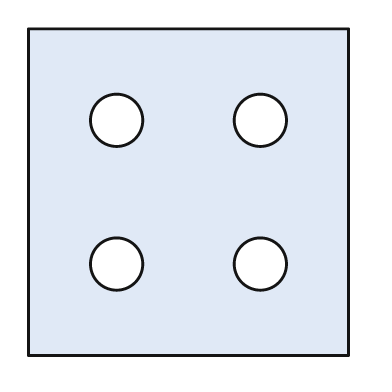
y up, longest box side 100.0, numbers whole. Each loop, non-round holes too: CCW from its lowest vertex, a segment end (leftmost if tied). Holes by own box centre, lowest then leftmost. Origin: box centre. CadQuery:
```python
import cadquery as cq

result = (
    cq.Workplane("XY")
    .moveTo(-49.0, -50.0)
    .lineTo(49.0, -50.0)
    .lineTo(49.0, 50.0)
    .lineTo(-49.0, 50.0)
    .close()
    .moveTo(-22.0, -22.0)
    .circle(8.0)
    .moveTo(22.0, -22.0)
    .circle(8.0)
    .moveTo(-22.0, 22.0)
    .circle(8.0)
    .moveTo(22.0, 22.0)
    .circle(8.0)
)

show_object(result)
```